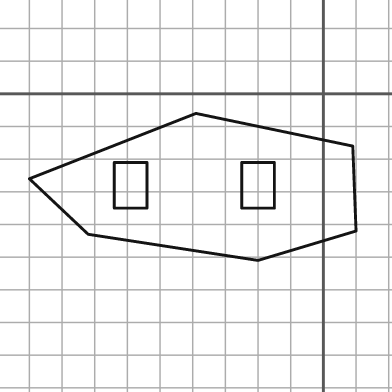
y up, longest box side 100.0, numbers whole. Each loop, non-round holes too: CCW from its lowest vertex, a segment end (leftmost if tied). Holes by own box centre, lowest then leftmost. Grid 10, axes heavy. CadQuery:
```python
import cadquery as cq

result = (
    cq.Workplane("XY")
    .moveTo(-20.0, -51.0)
    .lineTo(10.0, -42.0)
    .lineTo(9.0, -16.0)
    .lineTo(-39.0, -6.0)
    .lineTo(-90.0, -26.0)
    .lineTo(-72.0, -43.0)
    .close()
    .moveTo(-64.0, -35.0)
    .lineTo(-54.0, -35.0)
    .lineTo(-54.0, -21.0)
    .lineTo(-64.0, -21.0)
    .close()
    .moveTo(-25.0, -35.0)
    .lineTo(-15.0, -35.0)
    .lineTo(-15.0, -21.0)
    .lineTo(-25.0, -21.0)
    .close()
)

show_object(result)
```